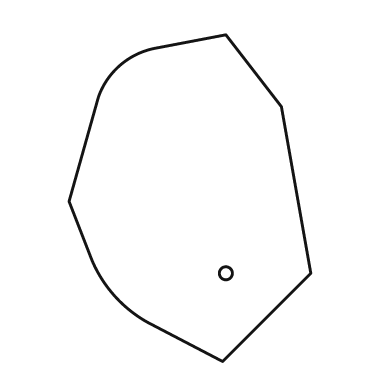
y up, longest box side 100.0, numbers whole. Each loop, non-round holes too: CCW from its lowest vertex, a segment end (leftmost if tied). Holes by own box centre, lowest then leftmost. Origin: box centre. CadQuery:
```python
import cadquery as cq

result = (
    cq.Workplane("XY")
    .moveTo(10.0, -50.0)
    .lineTo(37.0, -23.0)
    .lineTo(28.0, 28.0)
    .lineTo(11.0, 50.0)
    .lineTo(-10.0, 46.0)
    .threePointArc((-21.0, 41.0), (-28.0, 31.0))
    .lineTo(-37.0, -1.0)
    .lineTo(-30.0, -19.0)
    .threePointArc((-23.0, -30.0), (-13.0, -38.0))
    .close()
    .moveTo(11.0, -23.0)
    .circle(2.0)
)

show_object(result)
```